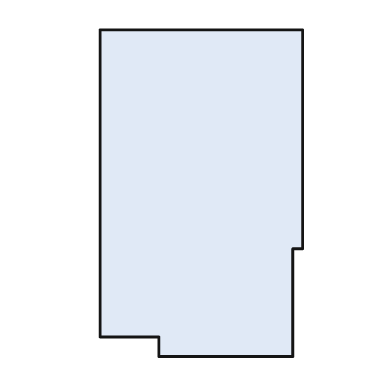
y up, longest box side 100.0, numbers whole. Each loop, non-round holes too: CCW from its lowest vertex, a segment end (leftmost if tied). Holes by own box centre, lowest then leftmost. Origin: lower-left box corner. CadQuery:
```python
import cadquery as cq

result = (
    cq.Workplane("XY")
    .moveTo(18.0, 0.0)
    .lineTo(59.0, 0.0)
    .lineTo(59.0, 33.0)
    .lineTo(62.0, 33.0)
    .lineTo(62.0, 100.0)
    .lineTo(0.0, 100.0)
    .lineTo(0.0, 6.0)
    .lineTo(18.0, 6.0)
    .close()
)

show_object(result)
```